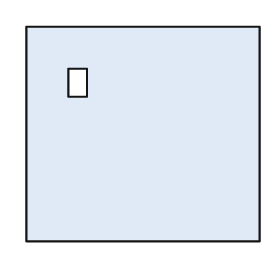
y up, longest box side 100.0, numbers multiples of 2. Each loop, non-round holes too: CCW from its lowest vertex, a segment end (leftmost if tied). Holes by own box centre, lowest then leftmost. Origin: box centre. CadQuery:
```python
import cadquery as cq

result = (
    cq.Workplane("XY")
    .moveTo(-50.0, -46.0)
    .lineTo(50.0, -46.0)
    .lineTo(50.0, 46.0)
    .lineTo(-50.0, 46.0)
    .close()
    .moveTo(-32.0, 16.0)
    .lineTo(-24.0, 16.0)
    .lineTo(-24.0, 28.0)
    .lineTo(-32.0, 28.0)
    .close()
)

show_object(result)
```